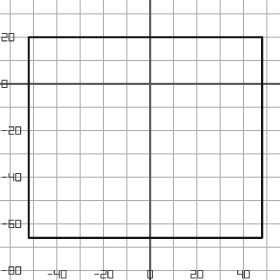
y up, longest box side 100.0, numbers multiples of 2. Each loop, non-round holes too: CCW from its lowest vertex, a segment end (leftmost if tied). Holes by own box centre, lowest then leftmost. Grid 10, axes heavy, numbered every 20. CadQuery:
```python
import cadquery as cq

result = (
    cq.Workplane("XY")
    .moveTo(-52.0, -66.0)
    .lineTo(48.0, -66.0)
    .lineTo(48.0, 20.0)
    .lineTo(-52.0, 20.0)
    .close()
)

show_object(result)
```